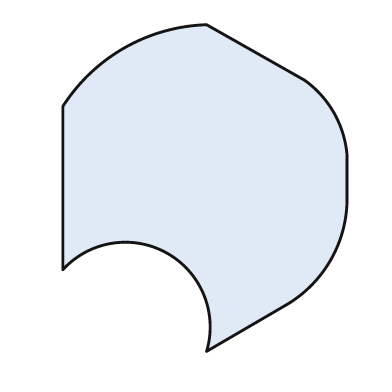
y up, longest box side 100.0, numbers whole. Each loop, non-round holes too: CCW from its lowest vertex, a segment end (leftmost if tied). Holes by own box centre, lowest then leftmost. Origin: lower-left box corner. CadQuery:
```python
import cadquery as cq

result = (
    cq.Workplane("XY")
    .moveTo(44.0, 0.0)
    .lineTo(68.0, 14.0)
    .threePointArc((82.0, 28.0), (87.0, 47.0))
    .lineTo(87.0, 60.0)
    .threePointArc((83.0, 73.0), (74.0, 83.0))
    .lineTo(44.0, 100.0)
    .threePointArc((19.0, 93.0), (0.0, 75.0))
    .lineTo(0.0, 25.0)
    .threePointArc((32.0, 30.0), (44.0, 0.0))
    .close()
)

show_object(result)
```